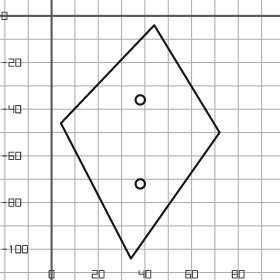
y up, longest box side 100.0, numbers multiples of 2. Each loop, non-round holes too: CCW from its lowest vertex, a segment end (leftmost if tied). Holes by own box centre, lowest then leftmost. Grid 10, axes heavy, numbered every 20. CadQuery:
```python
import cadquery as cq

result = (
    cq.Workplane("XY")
    .moveTo(34.0, -104.0)
    .lineTo(72.0, -50.0)
    .lineTo(44.0, -4.0)
    .lineTo(4.0, -46.0)
    .close()
    .moveTo(38.0, -72.0)
    .circle(2.0)
    .moveTo(38.0, -36.0)
    .circle(2.0)
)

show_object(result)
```